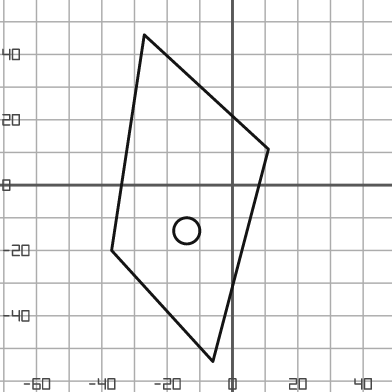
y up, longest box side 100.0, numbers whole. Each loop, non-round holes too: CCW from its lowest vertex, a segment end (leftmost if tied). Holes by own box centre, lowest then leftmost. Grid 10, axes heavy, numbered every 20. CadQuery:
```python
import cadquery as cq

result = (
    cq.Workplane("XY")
    .moveTo(-6.0, -54.0)
    .lineTo(11.0, 11.0)
    .lineTo(-27.0, 46.0)
    .lineTo(-37.0, -20.0)
    .close()
    .moveTo(-14.0, -14.0)
    .circle(4.0)
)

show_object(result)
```